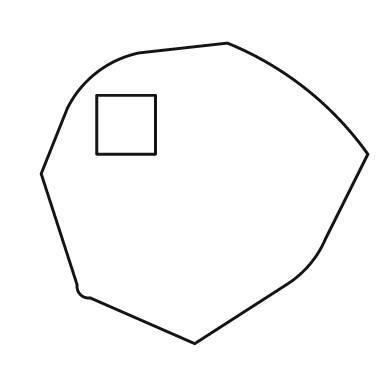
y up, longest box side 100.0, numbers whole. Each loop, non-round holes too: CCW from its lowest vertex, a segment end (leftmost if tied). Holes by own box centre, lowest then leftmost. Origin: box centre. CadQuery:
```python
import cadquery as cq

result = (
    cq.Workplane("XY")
    .moveTo(-3.0, -46.0)
    .lineTo(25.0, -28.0)
    .threePointArc((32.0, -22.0), (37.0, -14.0))
    .lineTo(50.0, 12.0)
    .threePointArc((31.0, 32.0), (7.0, 46.0))
    .lineTo(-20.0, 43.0)
    .threePointArc((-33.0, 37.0), (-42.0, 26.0))
    .lineTo(-50.0, 6.0)
    .lineTo(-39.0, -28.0)
    .threePointArc((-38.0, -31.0), (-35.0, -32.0))
    .close()
    .moveTo(-33.0, 12.0)
    .lineTo(-15.0, 12.0)
    .lineTo(-15.0, 30.0)
    .lineTo(-33.0, 30.0)
    .close()
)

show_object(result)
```